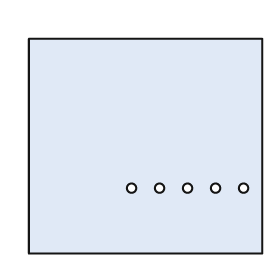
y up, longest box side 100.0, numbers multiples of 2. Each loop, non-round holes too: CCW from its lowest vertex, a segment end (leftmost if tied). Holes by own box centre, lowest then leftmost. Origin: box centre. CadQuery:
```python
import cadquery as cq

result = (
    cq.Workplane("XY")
    .moveTo(-50.0, -46.0)
    .lineTo(50.0, -46.0)
    .lineTo(50.0, 46.0)
    .lineTo(-50.0, 46.0)
    .close()
    .moveTo(-6.0, -18.0)
    .circle(2.0)
    .moveTo(6.0, -18.0)
    .circle(2.0)
    .moveTo(18.0, -18.0)
    .circle(2.0)
    .moveTo(30.0, -18.0)
    .circle(2.0)
    .moveTo(42.0, -18.0)
    .circle(2.0)
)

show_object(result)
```